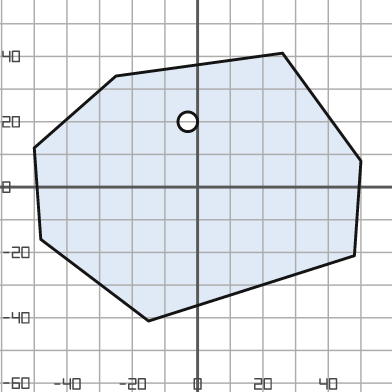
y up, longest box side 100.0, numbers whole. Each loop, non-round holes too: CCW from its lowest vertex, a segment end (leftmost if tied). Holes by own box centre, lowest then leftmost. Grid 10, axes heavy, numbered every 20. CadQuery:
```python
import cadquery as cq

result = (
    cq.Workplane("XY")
    .moveTo(-15.0, -41.0)
    .lineTo(48.0, -21.0)
    .lineTo(50.0, 8.0)
    .lineTo(26.0, 41.0)
    .lineTo(-25.0, 34.0)
    .lineTo(-50.0, 12.0)
    .lineTo(-48.0, -16.0)
    .close()
    .moveTo(-3.0, 20.0)
    .circle(3.0)
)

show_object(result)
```